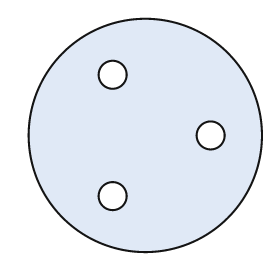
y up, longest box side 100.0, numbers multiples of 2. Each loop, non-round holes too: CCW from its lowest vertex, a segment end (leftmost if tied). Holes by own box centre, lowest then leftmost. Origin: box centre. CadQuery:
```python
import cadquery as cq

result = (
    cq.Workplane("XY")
    .moveTo(0.0, 0.0)
    .circle(50.0)
    .moveTo(-14.0, -26.0)
    .circle(6.0)
    .moveTo(28.0, 0.0)
    .circle(6.0)
    .moveTo(-14.0, 26.0)
    .circle(6.0)
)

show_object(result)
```